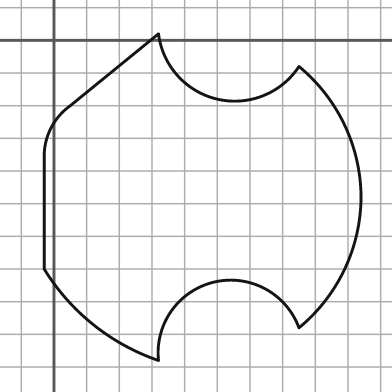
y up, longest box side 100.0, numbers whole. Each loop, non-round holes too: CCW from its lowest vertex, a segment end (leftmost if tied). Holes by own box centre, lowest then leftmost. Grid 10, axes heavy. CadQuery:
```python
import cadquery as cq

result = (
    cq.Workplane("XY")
    .moveTo(32.0, -98.0)
    .threePointArc((49.0, -74.0), (75.0, -88.0))
    .threePointArc((89.0, -70.0), (94.0, -48.0))
    .threePointArc((89.0, -26.0), (75.0, -8.0))
    .threePointArc((50.0, -18.0), (32.0, 2.0))
    .lineTo(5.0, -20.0)
    .threePointArc((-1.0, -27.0), (-3.0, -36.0))
    .lineTo(-3.0, -70.0)
    .threePointArc((12.0, -87.0), (32.0, -98.0))
    .close()
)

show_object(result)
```